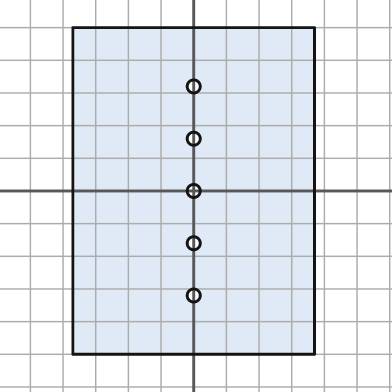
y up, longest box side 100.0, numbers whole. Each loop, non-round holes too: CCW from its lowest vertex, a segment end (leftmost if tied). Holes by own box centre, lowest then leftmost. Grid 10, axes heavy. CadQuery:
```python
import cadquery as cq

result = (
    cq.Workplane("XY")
    .moveTo(-37.0, -50.0)
    .lineTo(37.0, -50.0)
    .lineTo(37.0, 50.0)
    .lineTo(-37.0, 50.0)
    .close()
    .moveTo(0.0, -32.0)
    .circle(2.0)
    .moveTo(0.0, -16.0)
    .circle(2.0)
    .moveTo(0.0, 0.0)
    .circle(2.0)
    .moveTo(0.0, 16.0)
    .circle(2.0)
    .moveTo(0.0, 32.0)
    .circle(2.0)
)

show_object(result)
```